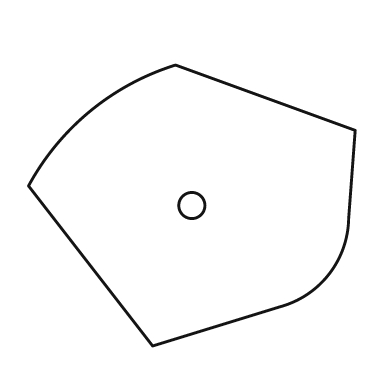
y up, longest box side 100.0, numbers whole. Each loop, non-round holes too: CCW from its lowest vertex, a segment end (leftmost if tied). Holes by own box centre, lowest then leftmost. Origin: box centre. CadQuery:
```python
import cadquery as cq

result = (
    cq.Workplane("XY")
    .moveTo(-12.0, -43.0)
    .lineTo(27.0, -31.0)
    .threePointArc((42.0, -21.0), (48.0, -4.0))
    .lineTo(50.0, 23.0)
    .lineTo(-5.0, 43.0)
    .threePointArc((-31.0, 29.0), (-50.0, 6.0))
    .close()
    .moveTo(0.0, 0.0)
    .circle(4.0)
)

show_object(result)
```